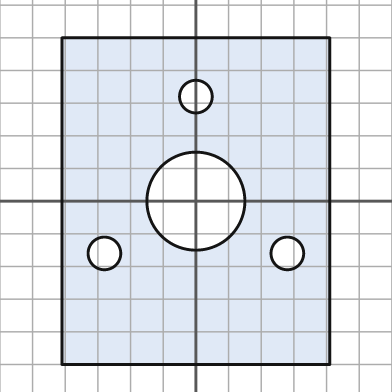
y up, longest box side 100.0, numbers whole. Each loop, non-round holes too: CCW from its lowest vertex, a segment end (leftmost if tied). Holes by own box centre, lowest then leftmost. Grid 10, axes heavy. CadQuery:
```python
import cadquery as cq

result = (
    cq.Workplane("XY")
    .moveTo(-41.0, -50.0)
    .lineTo(41.0, -50.0)
    .lineTo(41.0, 50.0)
    .lineTo(-41.0, 50.0)
    .close()
    .moveTo(-28.0, -16.0)
    .circle(5.0)
    .moveTo(28.0, -16.0)
    .circle(5.0)
    .moveTo(0.0, 0.0)
    .circle(15.0)
    .moveTo(0.0, 32.0)
    .circle(5.0)
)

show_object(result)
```